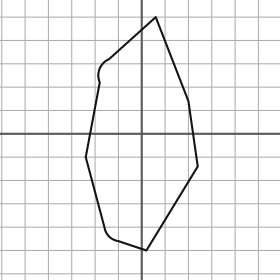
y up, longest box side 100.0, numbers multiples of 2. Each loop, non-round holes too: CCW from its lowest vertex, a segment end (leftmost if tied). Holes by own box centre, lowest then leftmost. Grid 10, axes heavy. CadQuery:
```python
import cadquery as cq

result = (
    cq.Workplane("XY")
    .moveTo(2.0, -50.0)
    .lineTo(24.0, -14.0)
    .lineTo(20.0, 14.0)
    .lineTo(6.0, 50.0)
    .lineTo(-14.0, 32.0)
    .threePointArc((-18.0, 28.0), (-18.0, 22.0))
    .lineTo(-24.0, -10.0)
    .lineTo(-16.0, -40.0)
    .threePointArc((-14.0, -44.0), (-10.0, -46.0))
    .close()
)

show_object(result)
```